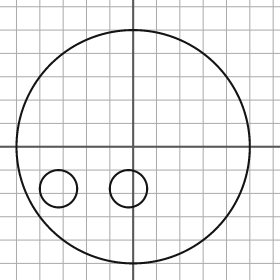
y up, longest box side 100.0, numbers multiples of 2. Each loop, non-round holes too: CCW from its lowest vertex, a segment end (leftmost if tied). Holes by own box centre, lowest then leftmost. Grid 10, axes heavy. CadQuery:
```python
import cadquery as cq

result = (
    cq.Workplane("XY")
    .moveTo(0.0, 0.0)
    .circle(50.0)
    .moveTo(-32.0, -18.0)
    .circle(8.0)
    .moveTo(-2.0, -18.0)
    .circle(8.0)
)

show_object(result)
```